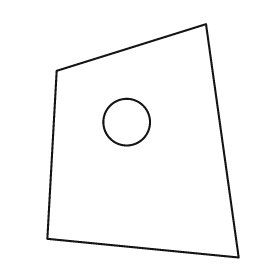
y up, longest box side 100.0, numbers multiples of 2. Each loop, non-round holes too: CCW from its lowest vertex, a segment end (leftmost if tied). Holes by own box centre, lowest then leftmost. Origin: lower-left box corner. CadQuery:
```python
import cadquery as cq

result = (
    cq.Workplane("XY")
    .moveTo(82.0, 0.0)
    .lineTo(68.0, 100.0)
    .lineTo(4.0, 80.0)
    .lineTo(0.0, 8.0)
    .close()
    .moveTo(34.0, 58.0)
    .circle(10.0)
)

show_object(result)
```